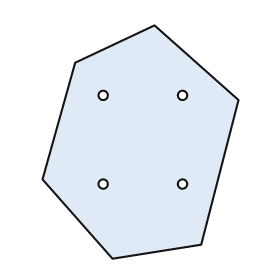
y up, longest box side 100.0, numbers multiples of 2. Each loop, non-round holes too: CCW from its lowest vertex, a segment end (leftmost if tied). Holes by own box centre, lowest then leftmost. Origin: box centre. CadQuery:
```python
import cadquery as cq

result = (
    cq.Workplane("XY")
    .moveTo(-12.0, -50.0)
    .lineTo(26.0, -44.0)
    .lineTo(42.0, 18.0)
    .lineTo(6.0, 50.0)
    .lineTo(-28.0, 34.0)
    .lineTo(-42.0, -16.0)
    .close()
    .moveTo(-16.0, -18.0)
    .circle(2.0)
    .moveTo(18.0, -18.0)
    .circle(2.0)
    .moveTo(-16.0, 20.0)
    .circle(2.0)
    .moveTo(18.0, 20.0)
    .circle(2.0)
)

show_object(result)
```